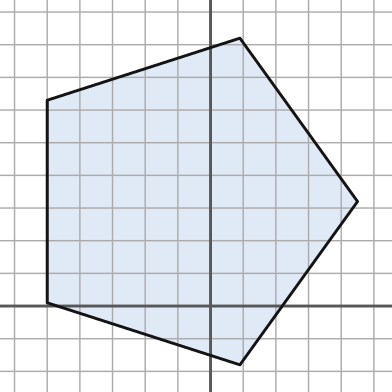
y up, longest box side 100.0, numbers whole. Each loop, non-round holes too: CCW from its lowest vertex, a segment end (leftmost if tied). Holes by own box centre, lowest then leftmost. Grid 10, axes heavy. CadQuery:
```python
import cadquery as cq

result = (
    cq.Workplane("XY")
    .moveTo(9.0, -18.0)
    .lineTo(45.0, 32.0)
    .lineTo(9.0, 82.0)
    .lineTo(-50.0, 63.0)
    .lineTo(-50.0, 1.0)
    .close()
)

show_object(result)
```